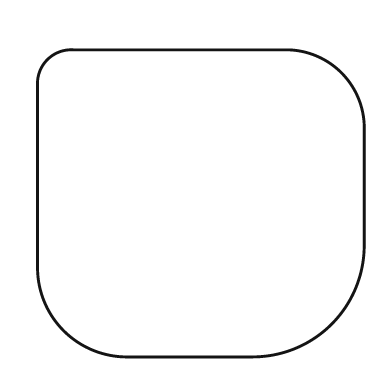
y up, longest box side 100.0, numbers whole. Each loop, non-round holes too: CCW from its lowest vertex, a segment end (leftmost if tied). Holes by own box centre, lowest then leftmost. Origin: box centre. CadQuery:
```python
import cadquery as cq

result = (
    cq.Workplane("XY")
    .moveTo(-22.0, -47.0)
    .lineTo(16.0, -47.0)
    .threePointArc((40.0, -37.0), (50.0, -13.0))
    .lineTo(50.0, 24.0)
    .threePointArc((43.0, 40.0), (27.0, 47.0))
    .lineTo(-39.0, 47.0)
    .threePointArc((-47.0, 44.0), (-50.0, 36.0))
    .lineTo(-50.0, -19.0)
    .threePointArc((-42.0, -39.0), (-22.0, -47.0))
    .close()
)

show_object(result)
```